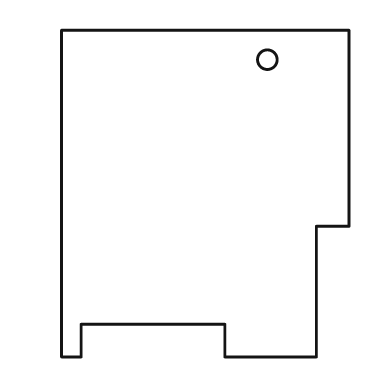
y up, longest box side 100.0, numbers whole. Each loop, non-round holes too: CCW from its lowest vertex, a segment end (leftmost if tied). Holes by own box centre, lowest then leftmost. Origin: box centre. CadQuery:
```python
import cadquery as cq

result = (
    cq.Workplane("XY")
    .moveTo(-44.0, -50.0)
    .lineTo(-38.0, -50.0)
    .lineTo(-38.0, -40.0)
    .lineTo(6.0, -40.0)
    .lineTo(6.0, -50.0)
    .lineTo(34.0, -50.0)
    .lineTo(34.0, -10.0)
    .lineTo(44.0, -10.0)
    .lineTo(44.0, 50.0)
    .lineTo(-44.0, 50.0)
    .close()
    .moveTo(19.0, 41.0)
    .circle(3.0)
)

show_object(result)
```